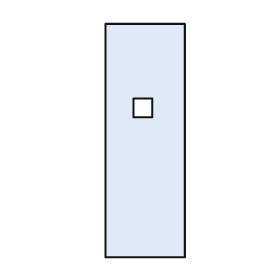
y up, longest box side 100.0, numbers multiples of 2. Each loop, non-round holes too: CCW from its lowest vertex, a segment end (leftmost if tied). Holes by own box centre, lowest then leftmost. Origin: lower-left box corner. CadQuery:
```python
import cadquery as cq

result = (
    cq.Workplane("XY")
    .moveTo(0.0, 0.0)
    .lineTo(34.0, 0.0)
    .lineTo(34.0, 100.0)
    .lineTo(0.0, 100.0)
    .close()
    .moveTo(12.0, 60.0)
    .lineTo(20.0, 60.0)
    .lineTo(20.0, 68.0)
    .lineTo(12.0, 68.0)
    .close()
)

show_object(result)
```